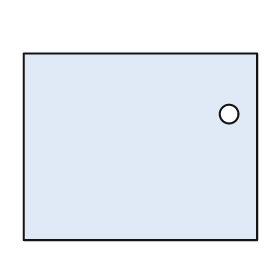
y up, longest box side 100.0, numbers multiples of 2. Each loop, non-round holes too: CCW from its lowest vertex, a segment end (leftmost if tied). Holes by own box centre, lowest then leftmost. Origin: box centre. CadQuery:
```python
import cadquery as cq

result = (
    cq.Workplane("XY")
    .moveTo(-50.0, -40.0)
    .lineTo(50.0, -40.0)
    .lineTo(50.0, 40.0)
    .lineTo(-50.0, 40.0)
    .close()
    .moveTo(38.0, 14.0)
    .circle(4.0)
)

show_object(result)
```